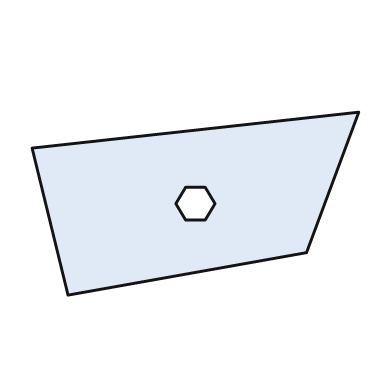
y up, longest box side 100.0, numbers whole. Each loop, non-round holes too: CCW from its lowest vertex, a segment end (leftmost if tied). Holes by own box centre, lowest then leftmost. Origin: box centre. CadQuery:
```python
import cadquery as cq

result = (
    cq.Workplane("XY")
    .moveTo(-39.0, -28.0)
    .lineTo(34.0, -15.0)
    .lineTo(50.0, 28.0)
    .lineTo(-50.0, 17.0)
    .close()
    .moveTo(-3.0, -5.0)
    .lineTo(3.0, -5.0)
    .lineTo(6.0, 0.0)
    .lineTo(3.0, 5.0)
    .lineTo(-3.0, 5.0)
    .lineTo(-6.0, 0.0)
    .close()
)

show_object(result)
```